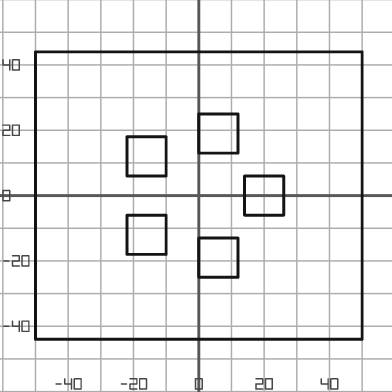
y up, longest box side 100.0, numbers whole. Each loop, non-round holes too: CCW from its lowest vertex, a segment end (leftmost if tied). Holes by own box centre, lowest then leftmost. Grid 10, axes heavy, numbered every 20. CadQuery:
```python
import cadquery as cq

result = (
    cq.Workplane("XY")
    .moveTo(-50.0, -44.0)
    .lineTo(50.0, -44.0)
    .lineTo(50.0, 44.0)
    .lineTo(-50.0, 44.0)
    .close()
    .moveTo(0.0, -25.0)
    .lineTo(12.0, -25.0)
    .lineTo(12.0, -13.0)
    .lineTo(0.0, -13.0)
    .close()
    .moveTo(-22.0, -18.0)
    .lineTo(-10.0, -18.0)
    .lineTo(-10.0, -6.0)
    .lineTo(-22.0, -6.0)
    .close()
    .moveTo(14.0, -6.0)
    .lineTo(26.0, -6.0)
    .lineTo(26.0, 6.0)
    .lineTo(14.0, 6.0)
    .close()
    .moveTo(-22.0, 6.0)
    .lineTo(-10.0, 6.0)
    .lineTo(-10.0, 18.0)
    .lineTo(-22.0, 18.0)
    .close()
    .moveTo(0.0, 13.0)
    .lineTo(12.0, 13.0)
    .lineTo(12.0, 25.0)
    .lineTo(0.0, 25.0)
    .close()
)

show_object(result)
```